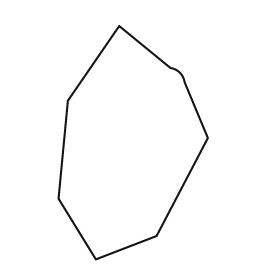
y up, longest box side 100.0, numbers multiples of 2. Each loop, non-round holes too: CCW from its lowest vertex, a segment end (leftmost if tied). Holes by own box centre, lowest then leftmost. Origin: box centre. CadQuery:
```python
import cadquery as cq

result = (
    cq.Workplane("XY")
    .moveTo(-16.0, -50.0)
    .lineTo(10.0, -40.0)
    .lineTo(32.0, 2.0)
    .lineTo(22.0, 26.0)
    .threePointArc((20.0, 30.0), (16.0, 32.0))
    .lineTo(-6.0, 50.0)
    .lineTo(-28.0, 18.0)
    .lineTo(-32.0, -24.0)
    .close()
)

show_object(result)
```